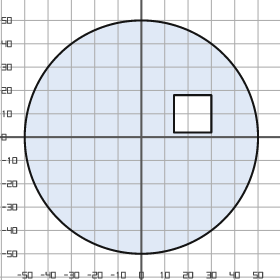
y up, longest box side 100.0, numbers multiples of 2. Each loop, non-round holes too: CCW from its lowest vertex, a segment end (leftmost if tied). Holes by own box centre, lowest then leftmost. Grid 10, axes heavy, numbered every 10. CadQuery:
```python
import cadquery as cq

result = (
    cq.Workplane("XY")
    .moveTo(0.0, 0.0)
    .circle(50.0)
    .moveTo(14.0, 2.0)
    .lineTo(30.0, 2.0)
    .lineTo(30.0, 18.0)
    .lineTo(14.0, 18.0)
    .close()
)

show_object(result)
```